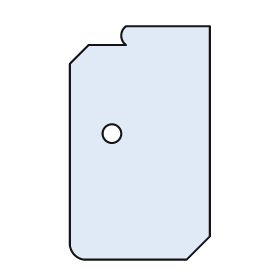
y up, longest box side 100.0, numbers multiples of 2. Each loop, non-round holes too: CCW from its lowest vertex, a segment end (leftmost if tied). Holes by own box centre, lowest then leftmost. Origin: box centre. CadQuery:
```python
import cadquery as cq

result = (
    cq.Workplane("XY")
    .moveTo(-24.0, -50.0)
    .lineTo(20.0, -50.0)
    .lineTo(30.0, -40.0)
    .lineTo(30.0, 50.0)
    .lineTo(-6.0, 50.0)
    .threePointArc((-8.0, 46.0), (-6.0, 42.0))
    .lineTo(-22.0, 42.0)
    .lineTo(-30.0, 34.0)
    .lineTo(-30.0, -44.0)
    .threePointArc((-28.0, -48.0), (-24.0, -50.0))
    .close()
    .moveTo(-12.0, 4.0)
    .circle(4.0)
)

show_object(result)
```